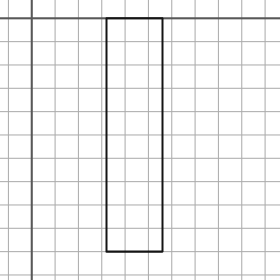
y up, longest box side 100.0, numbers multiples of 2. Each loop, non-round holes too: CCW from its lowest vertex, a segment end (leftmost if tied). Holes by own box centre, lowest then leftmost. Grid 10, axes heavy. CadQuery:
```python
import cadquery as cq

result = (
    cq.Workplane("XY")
    .moveTo(32.0, -100.0)
    .lineTo(56.0, -100.0)
    .lineTo(56.0, 0.0)
    .lineTo(32.0, 0.0)
    .close()
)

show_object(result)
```